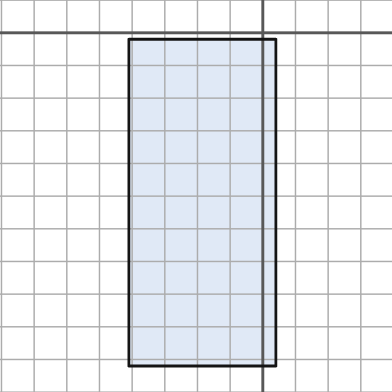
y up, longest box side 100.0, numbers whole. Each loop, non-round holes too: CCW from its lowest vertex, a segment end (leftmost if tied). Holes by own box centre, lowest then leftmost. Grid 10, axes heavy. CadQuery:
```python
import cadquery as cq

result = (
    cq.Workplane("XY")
    .moveTo(-41.0, -102.0)
    .lineTo(4.0, -102.0)
    .lineTo(4.0, -2.0)
    .lineTo(-41.0, -2.0)
    .close()
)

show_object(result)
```